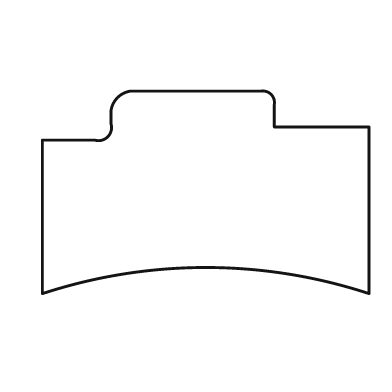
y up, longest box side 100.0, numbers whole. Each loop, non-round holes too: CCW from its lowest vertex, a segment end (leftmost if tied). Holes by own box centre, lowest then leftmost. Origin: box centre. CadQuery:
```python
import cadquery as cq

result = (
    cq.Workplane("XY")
    .moveTo(-50.0, -31.0)
    .threePointArc((0.0, -23.0), (50.0, -31.0))
    .lineTo(50.0, 20.0)
    .lineTo(21.0, 20.0)
    .lineTo(21.0, 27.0)
    .threePointArc((20.0, 30.0), (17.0, 31.0))
    .lineTo(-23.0, 31.0)
    .threePointArc((-27.0, 29.0), (-29.0, 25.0))
    .lineTo(-29.0, 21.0)
    .threePointArc((-30.0, 17.0), (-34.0, 16.0))
    .lineTo(-50.0, 16.0)
    .close()
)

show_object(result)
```